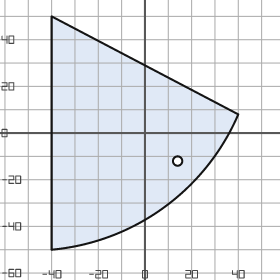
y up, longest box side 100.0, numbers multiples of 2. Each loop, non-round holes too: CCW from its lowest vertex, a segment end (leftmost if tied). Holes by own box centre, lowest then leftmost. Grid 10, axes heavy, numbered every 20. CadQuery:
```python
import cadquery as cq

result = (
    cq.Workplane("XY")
    .moveTo(-40.0, -50.0)
    .threePointArc((8.0, -32.0), (40.0, 8.0))
    .lineTo(-40.0, 50.0)
    .close()
    .moveTo(14.0, -12.0)
    .circle(2.0)
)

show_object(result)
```